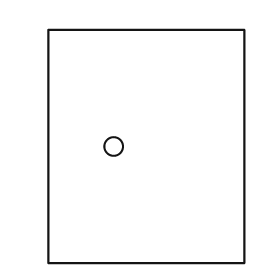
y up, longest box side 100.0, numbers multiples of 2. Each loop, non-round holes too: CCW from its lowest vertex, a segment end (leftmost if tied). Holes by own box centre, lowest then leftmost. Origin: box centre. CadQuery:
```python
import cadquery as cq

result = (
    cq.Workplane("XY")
    .moveTo(-42.0, -50.0)
    .lineTo(42.0, -50.0)
    .lineTo(42.0, 50.0)
    .lineTo(-42.0, 50.0)
    .close()
    .moveTo(-14.0, 0.0)
    .circle(4.0)
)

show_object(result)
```